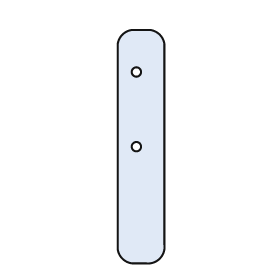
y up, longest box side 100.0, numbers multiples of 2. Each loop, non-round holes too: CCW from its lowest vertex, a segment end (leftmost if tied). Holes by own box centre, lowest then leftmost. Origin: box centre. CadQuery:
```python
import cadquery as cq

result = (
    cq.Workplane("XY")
    .moveTo(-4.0, -50.0)
    .lineTo(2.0, -50.0)
    .threePointArc((8.0, -48.0), (10.0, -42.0))
    .lineTo(10.0, 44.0)
    .threePointArc((8.0, 48.0), (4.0, 50.0))
    .lineTo(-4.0, 50.0)
    .threePointArc((-8.0, 48.0), (-10.0, 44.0))
    .lineTo(-10.0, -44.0)
    .threePointArc((-8.0, -48.0), (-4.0, -50.0))
    .close()
    .moveTo(-2.0, 0.0)
    .circle(2.0)
    .moveTo(-2.0, 32.0)
    .circle(2.0)
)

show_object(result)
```